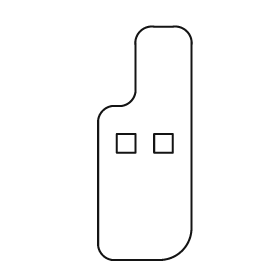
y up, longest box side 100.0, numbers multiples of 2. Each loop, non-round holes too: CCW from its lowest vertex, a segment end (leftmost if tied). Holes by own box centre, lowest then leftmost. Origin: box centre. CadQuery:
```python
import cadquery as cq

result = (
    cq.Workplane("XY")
    .moveTo(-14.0, -50.0)
    .lineTo(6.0, -50.0)
    .threePointArc((16.0, -46.0), (20.0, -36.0))
    .lineTo(20.0, 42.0)
    .threePointArc((18.0, 48.0), (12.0, 50.0))
    .lineTo(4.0, 50.0)
    .threePointArc((-2.0, 48.0), (-4.0, 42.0))
    .lineTo(-4.0, 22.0)
    .threePointArc((-6.0, 18.0), (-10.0, 16.0))
    .lineTo(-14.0, 16.0)
    .threePointArc((-18.0, 14.0), (-20.0, 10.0))
    .lineTo(-20.0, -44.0)
    .threePointArc((-18.0, -48.0), (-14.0, -50.0))
    .close()
    .moveTo(-12.0, -4.0)
    .lineTo(-4.0, -4.0)
    .lineTo(-4.0, 4.0)
    .lineTo(-12.0, 4.0)
    .close()
    .moveTo(4.0, -4.0)
    .lineTo(12.0, -4.0)
    .lineTo(12.0, 4.0)
    .lineTo(4.0, 4.0)
    .close()
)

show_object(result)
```